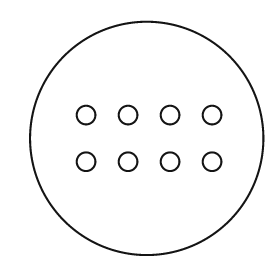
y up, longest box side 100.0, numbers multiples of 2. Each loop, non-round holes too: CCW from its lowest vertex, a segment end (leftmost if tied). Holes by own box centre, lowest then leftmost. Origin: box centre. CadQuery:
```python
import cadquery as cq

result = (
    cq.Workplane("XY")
    .moveTo(0.0, 0.0)
    .circle(50.0)
    .moveTo(-26.0, -10.0)
    .circle(4.0)
    .moveTo(-8.0, -10.0)
    .circle(4.0)
    .moveTo(10.0, -10.0)
    .circle(4.0)
    .moveTo(28.0, -10.0)
    .circle(4.0)
    .moveTo(-26.0, 10.0)
    .circle(4.0)
    .moveTo(-8.0, 10.0)
    .circle(4.0)
    .moveTo(10.0, 10.0)
    .circle(4.0)
    .moveTo(28.0, 10.0)
    .circle(4.0)
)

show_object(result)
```